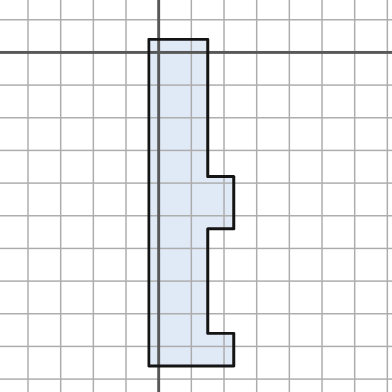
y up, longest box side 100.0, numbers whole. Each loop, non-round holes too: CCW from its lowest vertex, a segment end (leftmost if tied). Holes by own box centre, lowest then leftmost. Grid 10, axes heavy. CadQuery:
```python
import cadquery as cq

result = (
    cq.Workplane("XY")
    .moveTo(-3.0, -96.0)
    .lineTo(23.0, -96.0)
    .lineTo(23.0, -86.0)
    .lineTo(15.0, -86.0)
    .lineTo(15.0, -54.0)
    .lineTo(23.0, -54.0)
    .lineTo(23.0, -38.0)
    .lineTo(15.0, -38.0)
    .lineTo(15.0, 4.0)
    .lineTo(-3.0, 4.0)
    .close()
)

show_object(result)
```